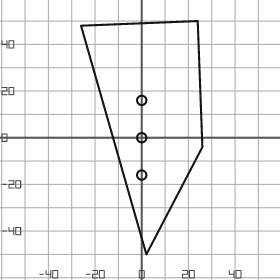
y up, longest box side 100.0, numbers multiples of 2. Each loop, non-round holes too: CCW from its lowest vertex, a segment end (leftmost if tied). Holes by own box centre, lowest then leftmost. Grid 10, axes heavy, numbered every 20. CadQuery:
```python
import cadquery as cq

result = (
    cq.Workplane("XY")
    .moveTo(2.0, -50.0)
    .lineTo(26.0, -4.0)
    .lineTo(24.0, 50.0)
    .lineTo(-26.0, 48.0)
    .close()
    .moveTo(0.0, -16.0)
    .circle(2.0)
    .moveTo(0.0, 0.0)
    .circle(2.0)
    .moveTo(0.0, 16.0)
    .circle(2.0)
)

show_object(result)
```